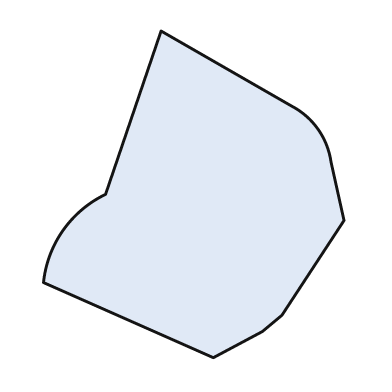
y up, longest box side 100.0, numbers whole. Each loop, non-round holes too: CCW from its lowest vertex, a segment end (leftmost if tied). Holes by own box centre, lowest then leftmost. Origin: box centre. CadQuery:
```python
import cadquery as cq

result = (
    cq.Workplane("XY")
    .moveTo(6.0, -50.0)
    .lineTo(21.0, -42.0)
    .lineTo(27.0, -37.0)
    .lineTo(46.0, -8.0)
    .lineTo(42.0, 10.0)
    .threePointArc((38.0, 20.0), (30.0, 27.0))
    .lineTo(-10.0, 50.0)
    .lineTo(-27.0, 0.0)
    .threePointArc((-40.0, -11.0), (-46.0, -27.0))
    .close()
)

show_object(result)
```